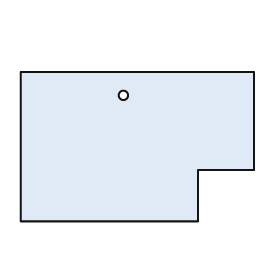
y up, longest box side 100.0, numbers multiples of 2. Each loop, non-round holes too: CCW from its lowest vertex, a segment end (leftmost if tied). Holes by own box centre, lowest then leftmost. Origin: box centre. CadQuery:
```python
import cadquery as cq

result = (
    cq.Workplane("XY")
    .moveTo(-50.0, -32.0)
    .lineTo(26.0, -32.0)
    .lineTo(26.0, -10.0)
    .lineTo(50.0, -10.0)
    .lineTo(50.0, 32.0)
    .lineTo(-50.0, 32.0)
    .close()
    .moveTo(-6.0, 22.0)
    .circle(2.0)
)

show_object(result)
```